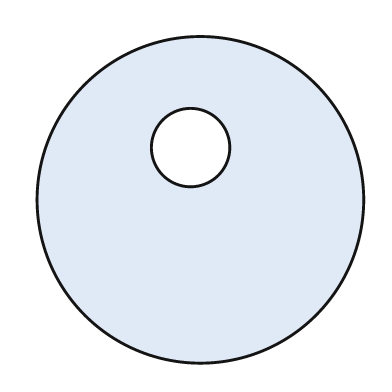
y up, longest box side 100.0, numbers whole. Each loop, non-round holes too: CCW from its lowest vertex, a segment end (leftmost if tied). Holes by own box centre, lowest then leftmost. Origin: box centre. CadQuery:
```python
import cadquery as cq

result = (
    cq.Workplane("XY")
    .moveTo(0.0, 0.0)
    .circle(50.0)
    .moveTo(-3.0, 16.0)
    .circle(12.0)
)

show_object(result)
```